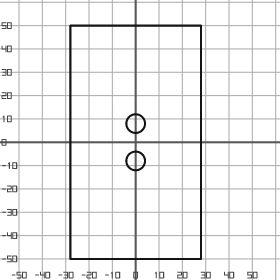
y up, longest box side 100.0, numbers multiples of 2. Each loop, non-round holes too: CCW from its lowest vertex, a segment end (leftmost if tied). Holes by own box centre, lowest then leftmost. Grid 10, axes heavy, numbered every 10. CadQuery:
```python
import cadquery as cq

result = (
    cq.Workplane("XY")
    .moveTo(-28.0, -50.0)
    .lineTo(28.0, -50.0)
    .lineTo(28.0, 50.0)
    .lineTo(-28.0, 50.0)
    .close()
    .moveTo(0.0, -8.0)
    .circle(4.0)
    .moveTo(0.0, 8.0)
    .circle(4.0)
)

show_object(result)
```